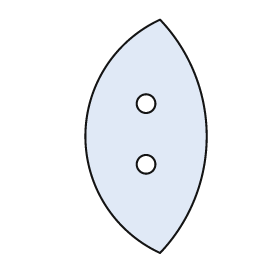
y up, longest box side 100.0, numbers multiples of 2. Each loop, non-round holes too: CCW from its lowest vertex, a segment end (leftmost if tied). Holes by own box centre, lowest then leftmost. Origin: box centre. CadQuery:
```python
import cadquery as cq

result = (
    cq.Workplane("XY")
    .moveTo(6.0, -50.0)
    .threePointArc((26.0, 0.0), (6.0, 50.0))
    .threePointArc((-26.0, 0.0), (6.0, -50.0))
    .close()
    .moveTo(0.0, -12.0)
    .circle(4.0)
    .moveTo(0.0, 14.0)
    .circle(4.0)
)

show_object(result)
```